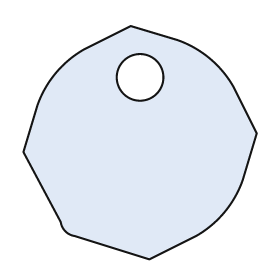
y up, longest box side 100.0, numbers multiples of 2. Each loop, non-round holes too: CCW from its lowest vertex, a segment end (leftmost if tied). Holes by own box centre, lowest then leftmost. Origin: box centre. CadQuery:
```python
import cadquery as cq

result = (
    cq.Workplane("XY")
    .moveTo(4.0, -50.0)
    .lineTo(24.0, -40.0)
    .threePointArc((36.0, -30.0), (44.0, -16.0))
    .lineTo(50.0, 4.0)
    .lineTo(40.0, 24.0)
    .threePointArc((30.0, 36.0), (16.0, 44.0))
    .lineTo(-4.0, 50.0)
    .lineTo(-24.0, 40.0)
    .threePointArc((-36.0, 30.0), (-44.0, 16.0))
    .lineTo(-50.0, -4.0)
    .lineTo(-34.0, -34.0)
    .threePointArc((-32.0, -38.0), (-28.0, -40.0))
    .close()
    .moveTo(0.0, 28.0)
    .circle(10.0)
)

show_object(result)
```